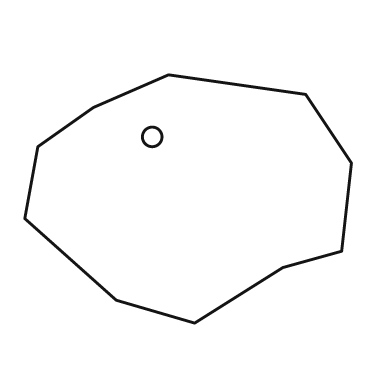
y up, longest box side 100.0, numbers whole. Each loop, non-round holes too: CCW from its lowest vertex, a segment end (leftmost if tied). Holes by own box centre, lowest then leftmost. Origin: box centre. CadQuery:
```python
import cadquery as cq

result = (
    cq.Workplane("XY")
    .moveTo(2.0, -38.0)
    .lineTo(29.0, -21.0)
    .lineTo(47.0, -16.0)
    .lineTo(50.0, 11.0)
    .lineTo(36.0, 32.0)
    .lineTo(-6.0, 38.0)
    .lineTo(-29.0, 28.0)
    .lineTo(-46.0, 16.0)
    .lineTo(-50.0, -6.0)
    .lineTo(-22.0, -31.0)
    .close()
    .moveTo(-11.0, 19.0)
    .circle(3.0)
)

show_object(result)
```